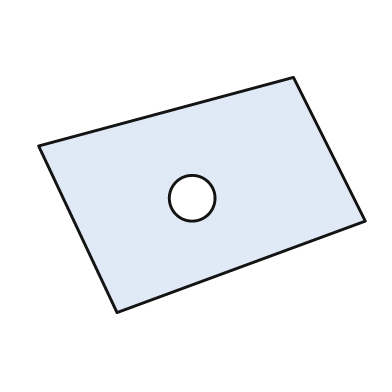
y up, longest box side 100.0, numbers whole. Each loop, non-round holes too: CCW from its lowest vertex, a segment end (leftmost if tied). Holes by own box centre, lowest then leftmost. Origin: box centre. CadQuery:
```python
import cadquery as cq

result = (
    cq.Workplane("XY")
    .moveTo(-26.0, -36.0)
    .lineTo(50.0, -8.0)
    .lineTo(28.0, 36.0)
    .lineTo(-50.0, 15.0)
    .close()
    .moveTo(-3.0, -1.0)
    .circle(7.0)
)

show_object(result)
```